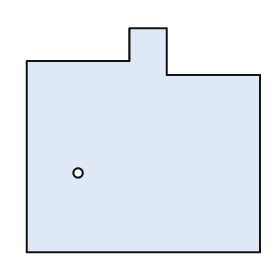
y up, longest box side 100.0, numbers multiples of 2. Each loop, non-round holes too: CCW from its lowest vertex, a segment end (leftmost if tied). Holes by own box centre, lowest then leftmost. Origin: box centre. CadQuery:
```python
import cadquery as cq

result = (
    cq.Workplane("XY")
    .moveTo(-50.0, -48.0)
    .lineTo(50.0, -48.0)
    .lineTo(50.0, 28.0)
    .lineTo(10.0, 28.0)
    .lineTo(10.0, 48.0)
    .lineTo(-6.0, 48.0)
    .lineTo(-6.0, 34.0)
    .lineTo(-50.0, 34.0)
    .close()
    .moveTo(-28.0, -14.0)
    .circle(2.0)
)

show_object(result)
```